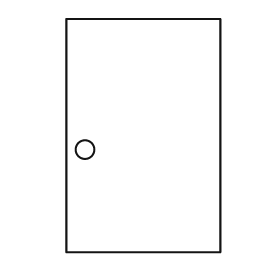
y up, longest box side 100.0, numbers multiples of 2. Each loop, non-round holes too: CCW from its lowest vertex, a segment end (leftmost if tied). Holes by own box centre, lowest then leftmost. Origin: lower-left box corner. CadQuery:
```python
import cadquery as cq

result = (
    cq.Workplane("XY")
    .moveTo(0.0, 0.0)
    .lineTo(66.0, 0.0)
    .lineTo(66.0, 100.0)
    .lineTo(0.0, 100.0)
    .close()
    .moveTo(8.0, 44.0)
    .circle(4.0)
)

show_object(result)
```